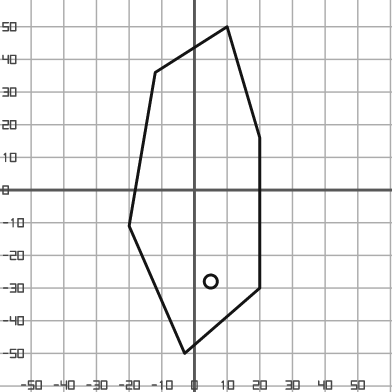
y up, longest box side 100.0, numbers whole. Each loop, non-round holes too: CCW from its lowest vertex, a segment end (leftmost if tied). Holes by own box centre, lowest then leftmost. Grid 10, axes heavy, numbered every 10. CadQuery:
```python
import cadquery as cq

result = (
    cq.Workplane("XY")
    .moveTo(-3.0, -50.0)
    .lineTo(20.0, -30.0)
    .lineTo(20.0, 16.0)
    .lineTo(10.0, 50.0)
    .lineTo(-12.0, 36.0)
    .lineTo(-20.0, -11.0)
    .close()
    .moveTo(5.0, -28.0)
    .circle(2.0)
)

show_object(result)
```